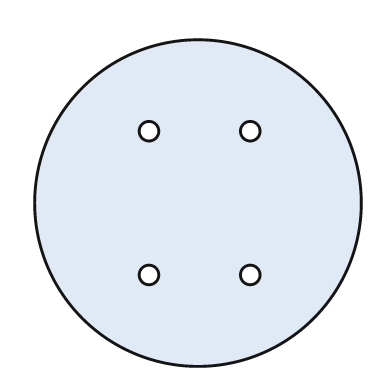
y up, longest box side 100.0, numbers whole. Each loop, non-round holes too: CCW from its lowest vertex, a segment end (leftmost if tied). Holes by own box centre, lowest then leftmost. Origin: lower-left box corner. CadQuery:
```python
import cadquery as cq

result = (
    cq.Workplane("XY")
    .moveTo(50.0, 50.0)
    .circle(50.0)
    .moveTo(35.0, 28.0)
    .circle(3.0)
    .moveTo(66.0, 28.0)
    .circle(3.0)
    .moveTo(35.0, 72.0)
    .circle(3.0)
    .moveTo(66.0, 72.0)
    .circle(3.0)
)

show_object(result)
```